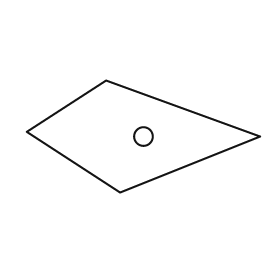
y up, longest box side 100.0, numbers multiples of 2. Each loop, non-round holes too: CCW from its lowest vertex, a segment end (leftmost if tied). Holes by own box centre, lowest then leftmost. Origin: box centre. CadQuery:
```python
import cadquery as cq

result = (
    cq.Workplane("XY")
    .moveTo(-10.0, -24.0)
    .lineTo(50.0, 0.0)
    .lineTo(-16.0, 24.0)
    .lineTo(-50.0, 2.0)
    .close()
    .moveTo(0.0, 0.0)
    .circle(4.0)
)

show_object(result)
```